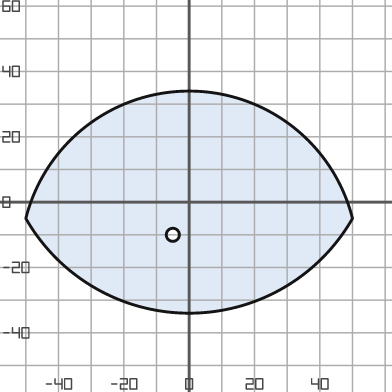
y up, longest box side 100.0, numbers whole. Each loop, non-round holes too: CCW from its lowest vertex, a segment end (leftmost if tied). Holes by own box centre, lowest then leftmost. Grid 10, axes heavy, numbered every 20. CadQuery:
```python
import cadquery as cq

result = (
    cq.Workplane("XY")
    .moveTo(-50.0, -5.0)
    .threePointArc((0.0, -34.0), (50.0, -5.0))
    .threePointArc((0.0, 34.0), (-50.0, -5.0))
    .close()
    .moveTo(-5.0, -10.0)
    .circle(2.0)
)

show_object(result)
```